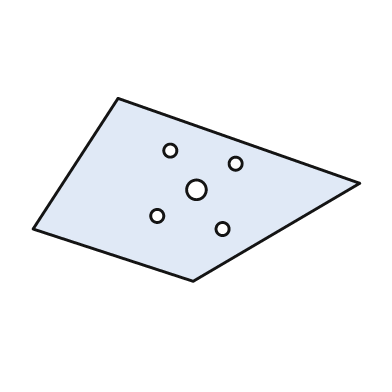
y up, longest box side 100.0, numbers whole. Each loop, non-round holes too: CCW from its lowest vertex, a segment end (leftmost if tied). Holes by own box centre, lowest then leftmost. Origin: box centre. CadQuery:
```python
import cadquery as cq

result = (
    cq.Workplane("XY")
    .moveTo(-1.0, -28.0)
    .lineTo(50.0, 2.0)
    .lineTo(-24.0, 28.0)
    .lineTo(-50.0, -12.0)
    .close()
    .moveTo(8.0, -12.0)
    .circle(2.0)
    .moveTo(-12.0, -8.0)
    .circle(2.0)
    .moveTo(0.0, 0.0)
    .circle(3.0)
    .moveTo(12.0, 8.0)
    .circle(2.0)
    .moveTo(-8.0, 12.0)
    .circle(2.0)
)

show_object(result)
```